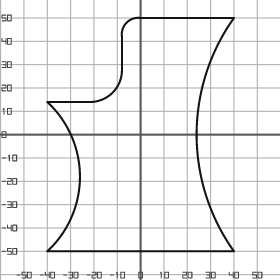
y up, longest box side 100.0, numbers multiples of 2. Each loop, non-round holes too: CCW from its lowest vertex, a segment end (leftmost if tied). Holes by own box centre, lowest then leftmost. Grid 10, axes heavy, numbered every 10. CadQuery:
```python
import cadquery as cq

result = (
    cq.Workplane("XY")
    .moveTo(-40.0, -50.0)
    .lineTo(40.0, -50.0)
    .threePointArc((24.0, 0.0), (40.0, 50.0))
    .lineTo(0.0, 50.0)
    .threePointArc((-6.0, 48.0), (-8.0, 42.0))
    .lineTo(-8.0, 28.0)
    .threePointArc((-12.0, 18.0), (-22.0, 14.0))
    .lineTo(-40.0, 14.0)
    .threePointArc((-26.0, -18.0), (-40.0, -50.0))
    .close()
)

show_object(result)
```